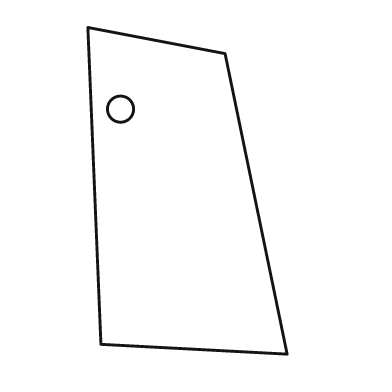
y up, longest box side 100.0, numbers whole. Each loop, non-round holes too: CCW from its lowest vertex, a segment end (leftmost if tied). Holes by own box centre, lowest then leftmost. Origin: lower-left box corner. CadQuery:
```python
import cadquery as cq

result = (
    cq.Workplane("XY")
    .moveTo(61.0, 0.0)
    .lineTo(42.0, 92.0)
    .lineTo(0.0, 100.0)
    .lineTo(4.0, 3.0)
    .close()
    .moveTo(10.0, 75.0)
    .circle(4.0)
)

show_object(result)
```